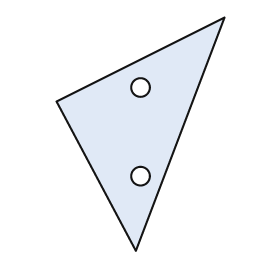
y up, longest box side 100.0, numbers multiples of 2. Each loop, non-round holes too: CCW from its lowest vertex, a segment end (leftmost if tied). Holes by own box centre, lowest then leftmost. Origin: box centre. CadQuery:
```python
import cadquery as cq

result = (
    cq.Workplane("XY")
    .moveTo(-2.0, -50.0)
    .lineTo(36.0, 50.0)
    .lineTo(-36.0, 14.0)
    .close()
    .moveTo(0.0, -18.0)
    .circle(4.0)
    .moveTo(0.0, 20.0)
    .circle(4.0)
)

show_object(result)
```